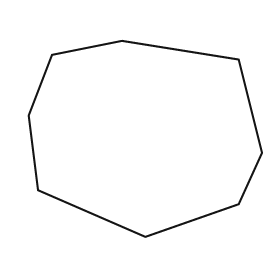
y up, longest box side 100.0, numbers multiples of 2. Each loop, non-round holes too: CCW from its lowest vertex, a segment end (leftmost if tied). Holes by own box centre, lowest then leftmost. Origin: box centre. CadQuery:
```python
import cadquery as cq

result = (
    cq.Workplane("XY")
    .moveTo(0.0, -42.0)
    .lineTo(40.0, -28.0)
    .lineTo(50.0, -6.0)
    .lineTo(40.0, 34.0)
    .lineTo(-10.0, 42.0)
    .lineTo(-40.0, 36.0)
    .lineTo(-50.0, 10.0)
    .lineTo(-46.0, -22.0)
    .close()
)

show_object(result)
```